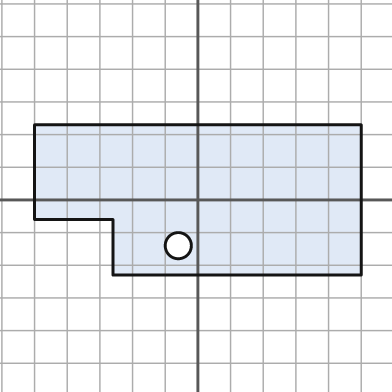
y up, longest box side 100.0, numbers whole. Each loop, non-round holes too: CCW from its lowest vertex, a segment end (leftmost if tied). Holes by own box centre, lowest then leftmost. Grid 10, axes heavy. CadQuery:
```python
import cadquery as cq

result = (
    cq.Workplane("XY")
    .moveTo(-26.0, -23.0)
    .lineTo(50.0, -23.0)
    .lineTo(50.0, 23.0)
    .lineTo(-50.0, 23.0)
    .lineTo(-50.0, -6.0)
    .lineTo(-26.0, -6.0)
    .close()
    .moveTo(-6.0, -14.0)
    .circle(4.0)
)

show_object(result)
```